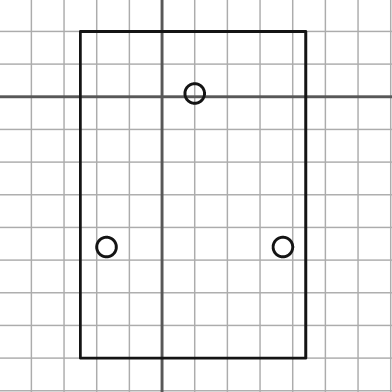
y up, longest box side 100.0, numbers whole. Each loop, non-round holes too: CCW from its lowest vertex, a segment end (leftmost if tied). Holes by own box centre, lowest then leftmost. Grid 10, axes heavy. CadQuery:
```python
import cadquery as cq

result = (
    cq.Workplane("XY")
    .moveTo(-25.0, -80.0)
    .lineTo(44.0, -80.0)
    .lineTo(44.0, 20.0)
    .lineTo(-25.0, 20.0)
    .close()
    .moveTo(-17.0, -46.0)
    .circle(3.0)
    .moveTo(37.0, -46.0)
    .circle(3.0)
    .moveTo(10.0, 1.0)
    .circle(3.0)
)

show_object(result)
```